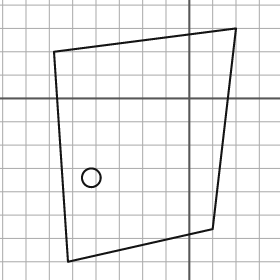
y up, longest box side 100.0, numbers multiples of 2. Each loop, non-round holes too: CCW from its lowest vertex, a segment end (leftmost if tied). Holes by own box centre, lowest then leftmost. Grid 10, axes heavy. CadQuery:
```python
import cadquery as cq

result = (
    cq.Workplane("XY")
    .moveTo(-52.0, -70.0)
    .lineTo(10.0, -56.0)
    .lineTo(20.0, 30.0)
    .lineTo(-58.0, 20.0)
    .close()
    .moveTo(-42.0, -34.0)
    .circle(4.0)
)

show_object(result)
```